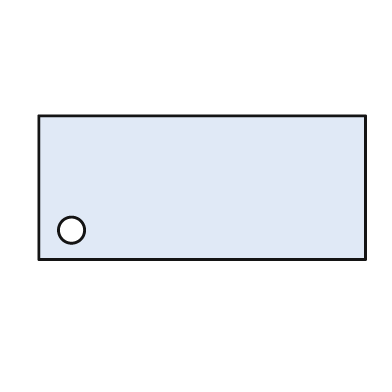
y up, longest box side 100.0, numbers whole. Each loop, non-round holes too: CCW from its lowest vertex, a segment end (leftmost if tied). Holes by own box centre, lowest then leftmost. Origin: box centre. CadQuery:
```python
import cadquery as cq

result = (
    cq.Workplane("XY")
    .moveTo(-50.0, -22.0)
    .lineTo(50.0, -22.0)
    .lineTo(50.0, 22.0)
    .lineTo(-50.0, 22.0)
    .close()
    .moveTo(-40.0, -13.0)
    .circle(4.0)
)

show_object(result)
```